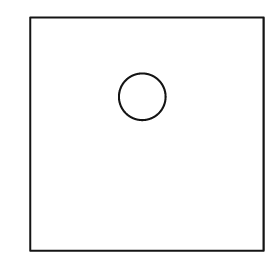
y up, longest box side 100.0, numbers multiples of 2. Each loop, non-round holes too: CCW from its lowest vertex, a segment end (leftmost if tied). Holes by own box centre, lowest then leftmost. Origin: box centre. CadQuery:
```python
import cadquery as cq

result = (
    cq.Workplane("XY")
    .moveTo(-50.0, -50.0)
    .lineTo(50.0, -50.0)
    .lineTo(50.0, 50.0)
    .lineTo(-50.0, 50.0)
    .close()
    .moveTo(-2.0, 16.0)
    .circle(10.0)
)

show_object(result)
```